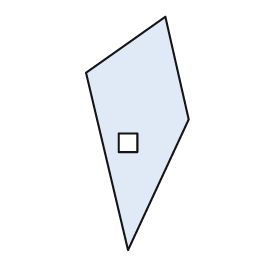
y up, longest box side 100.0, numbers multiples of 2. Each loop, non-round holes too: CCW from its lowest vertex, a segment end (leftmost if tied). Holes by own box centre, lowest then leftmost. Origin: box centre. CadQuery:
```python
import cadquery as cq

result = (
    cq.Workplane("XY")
    .moveTo(-4.0, -50.0)
    .lineTo(22.0, 6.0)
    .lineTo(12.0, 50.0)
    .lineTo(-22.0, 26.0)
    .close()
    .moveTo(-8.0, -8.0)
    .lineTo(0.0, -8.0)
    .lineTo(0.0, 0.0)
    .lineTo(-8.0, 0.0)
    .close()
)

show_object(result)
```